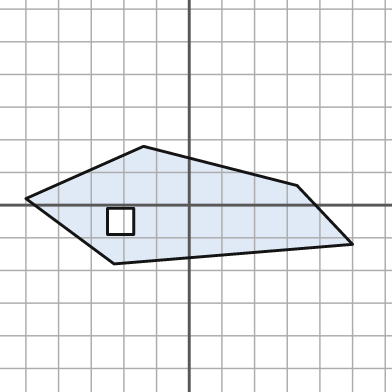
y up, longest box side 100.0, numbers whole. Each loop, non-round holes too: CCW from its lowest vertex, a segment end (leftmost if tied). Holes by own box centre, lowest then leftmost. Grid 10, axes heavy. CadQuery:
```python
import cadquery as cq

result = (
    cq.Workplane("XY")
    .moveTo(-23.0, -18.0)
    .lineTo(50.0, -12.0)
    .lineTo(33.0, 6.0)
    .lineTo(-14.0, 18.0)
    .lineTo(-50.0, 2.0)
    .close()
    .moveTo(-25.0, -9.0)
    .lineTo(-17.0, -9.0)
    .lineTo(-17.0, -1.0)
    .lineTo(-25.0, -1.0)
    .close()
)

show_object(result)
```